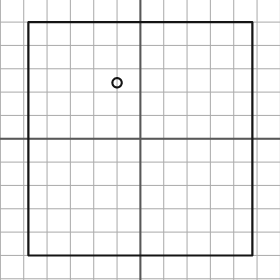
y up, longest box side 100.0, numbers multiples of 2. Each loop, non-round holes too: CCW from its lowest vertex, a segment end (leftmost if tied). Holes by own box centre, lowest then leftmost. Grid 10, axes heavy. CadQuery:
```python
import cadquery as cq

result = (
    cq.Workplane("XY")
    .moveTo(-48.0, -50.0)
    .lineTo(48.0, -50.0)
    .lineTo(48.0, 50.0)
    .lineTo(-48.0, 50.0)
    .close()
    .moveTo(-10.0, 24.0)
    .circle(2.0)
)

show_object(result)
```